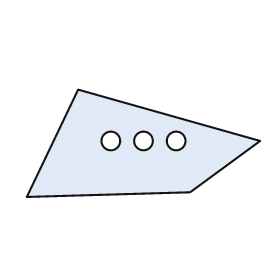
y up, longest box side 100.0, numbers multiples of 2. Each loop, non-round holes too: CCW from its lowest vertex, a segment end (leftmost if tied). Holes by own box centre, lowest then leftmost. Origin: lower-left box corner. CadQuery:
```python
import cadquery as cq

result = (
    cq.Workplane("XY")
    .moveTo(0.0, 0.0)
    .lineTo(70.0, 2.0)
    .lineTo(100.0, 24.0)
    .lineTo(22.0, 46.0)
    .close()
    .moveTo(36.0, 24.0)
    .circle(4.0)
    .moveTo(50.0, 24.0)
    .circle(4.0)
    .moveTo(64.0, 24.0)
    .circle(4.0)
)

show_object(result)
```